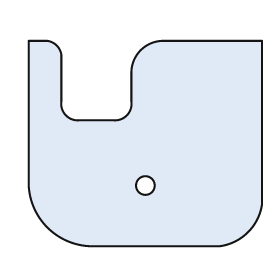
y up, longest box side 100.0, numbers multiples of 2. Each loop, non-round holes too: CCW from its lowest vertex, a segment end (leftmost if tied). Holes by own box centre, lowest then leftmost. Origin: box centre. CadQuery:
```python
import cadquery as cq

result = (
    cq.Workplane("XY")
    .moveTo(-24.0, -44.0)
    .lineTo(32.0, -44.0)
    .threePointArc((44.0, -38.0), (50.0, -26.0))
    .lineTo(50.0, 44.0)
    .lineTo(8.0, 44.0)
    .threePointArc((-2.0, 40.0), (-6.0, 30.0))
    .lineTo(-6.0, 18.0)
    .threePointArc((-8.0, 12.0), (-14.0, 10.0))
    .lineTo(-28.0, 10.0)
    .threePointArc((-34.0, 12.0), (-36.0, 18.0))
    .lineTo(-36.0, 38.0)
    .threePointArc((-38.0, 42.0), (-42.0, 44.0))
    .lineTo(-50.0, 44.0)
    .lineTo(-50.0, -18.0)
    .threePointArc((-42.0, -36.0), (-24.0, -44.0))
    .close()
    .moveTo(0.0, -18.0)
    .circle(4.0)
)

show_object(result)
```